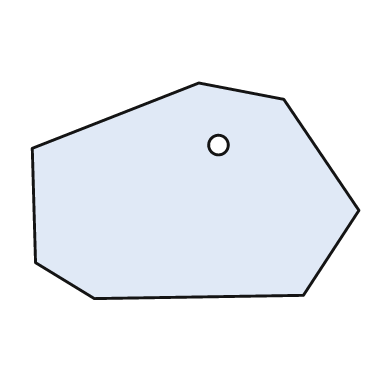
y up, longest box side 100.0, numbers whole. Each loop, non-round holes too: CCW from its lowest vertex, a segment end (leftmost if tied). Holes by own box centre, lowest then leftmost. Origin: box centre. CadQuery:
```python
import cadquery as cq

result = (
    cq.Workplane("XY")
    .moveTo(-31.0, -33.0)
    .lineTo(33.0, -32.0)
    .lineTo(50.0, -6.0)
    .lineTo(27.0, 28.0)
    .lineTo(1.0, 33.0)
    .lineTo(-50.0, 13.0)
    .lineTo(-49.0, -22.0)
    .close()
    .moveTo(7.0, 14.0)
    .circle(3.0)
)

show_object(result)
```